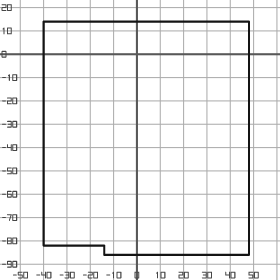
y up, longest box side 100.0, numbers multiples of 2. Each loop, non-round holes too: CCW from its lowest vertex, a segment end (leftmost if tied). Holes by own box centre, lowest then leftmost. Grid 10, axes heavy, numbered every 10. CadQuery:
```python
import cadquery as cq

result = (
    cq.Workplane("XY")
    .moveTo(-14.0, -86.0)
    .lineTo(48.0, -86.0)
    .lineTo(48.0, 14.0)
    .lineTo(-40.0, 14.0)
    .lineTo(-40.0, -82.0)
    .lineTo(-14.0, -82.0)
    .close()
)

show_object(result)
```